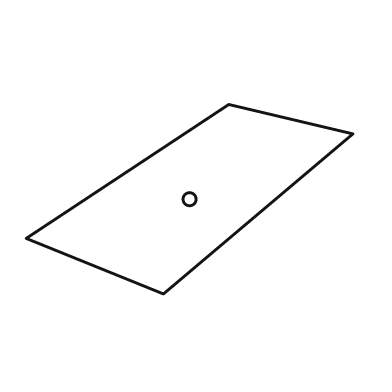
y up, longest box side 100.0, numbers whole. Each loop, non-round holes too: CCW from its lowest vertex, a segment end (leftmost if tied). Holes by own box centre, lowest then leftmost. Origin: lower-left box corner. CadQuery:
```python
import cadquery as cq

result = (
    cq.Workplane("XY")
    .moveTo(42.0, 0.0)
    .lineTo(100.0, 49.0)
    .lineTo(62.0, 58.0)
    .lineTo(0.0, 17.0)
    .close()
    .moveTo(50.0, 29.0)
    .circle(2.0)
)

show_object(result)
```